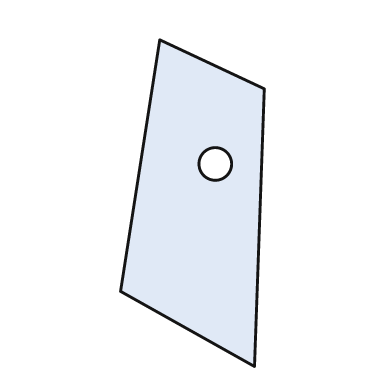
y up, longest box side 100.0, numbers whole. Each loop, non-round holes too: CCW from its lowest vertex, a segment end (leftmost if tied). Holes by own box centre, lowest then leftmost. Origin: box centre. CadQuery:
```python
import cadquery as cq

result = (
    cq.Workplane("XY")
    .moveTo(19.0, -50.0)
    .lineTo(22.0, 35.0)
    .lineTo(-10.0, 50.0)
    .lineTo(-22.0, -27.0)
    .close()
    .moveTo(7.0, 12.0)
    .circle(5.0)
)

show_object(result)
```